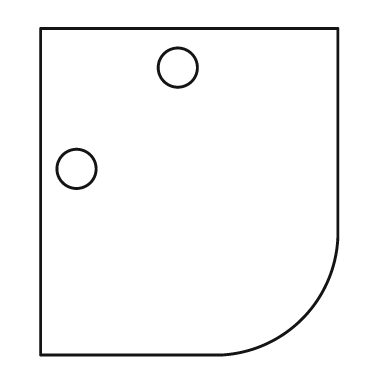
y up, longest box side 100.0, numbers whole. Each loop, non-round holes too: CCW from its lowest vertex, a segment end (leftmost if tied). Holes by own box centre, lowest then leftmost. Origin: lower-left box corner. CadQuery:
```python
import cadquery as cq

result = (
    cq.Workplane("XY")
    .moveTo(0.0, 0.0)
    .lineTo(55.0, 0.0)
    .threePointArc((80.0, 11.0), (91.0, 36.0))
    .lineTo(91.0, 100.0)
    .lineTo(0.0, 100.0)
    .close()
    .moveTo(11.0, 57.0)
    .circle(6.0)
    .moveTo(42.0, 88.0)
    .circle(6.0)
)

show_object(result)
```